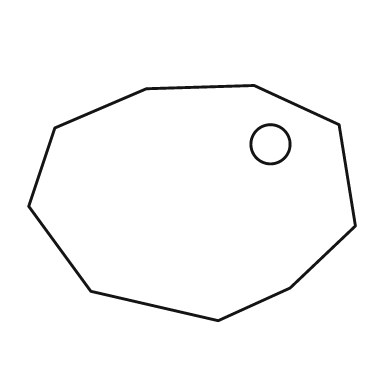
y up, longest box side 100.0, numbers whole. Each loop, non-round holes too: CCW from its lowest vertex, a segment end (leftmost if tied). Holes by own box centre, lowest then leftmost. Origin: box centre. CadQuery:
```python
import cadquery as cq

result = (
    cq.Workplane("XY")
    .moveTo(8.0, -36.0)
    .lineTo(30.0, -26.0)
    .lineTo(50.0, -7.0)
    .lineTo(45.0, 24.0)
    .lineTo(19.0, 36.0)
    .lineTo(-14.0, 35.0)
    .lineTo(-42.0, 23.0)
    .lineTo(-50.0, -1.0)
    .lineTo(-31.0, -27.0)
    .close()
    .moveTo(24.0, 18.0)
    .circle(6.0)
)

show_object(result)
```